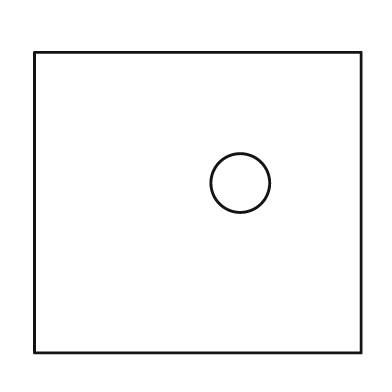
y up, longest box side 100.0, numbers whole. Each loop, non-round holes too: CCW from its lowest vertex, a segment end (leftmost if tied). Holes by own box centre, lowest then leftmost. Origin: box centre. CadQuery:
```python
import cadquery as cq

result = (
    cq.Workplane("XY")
    .moveTo(-50.0, -46.0)
    .lineTo(50.0, -46.0)
    .lineTo(50.0, 46.0)
    .lineTo(-50.0, 46.0)
    .close()
    .moveTo(13.0, 6.0)
    .circle(9.0)
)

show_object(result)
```